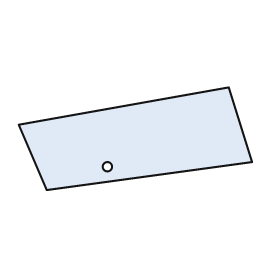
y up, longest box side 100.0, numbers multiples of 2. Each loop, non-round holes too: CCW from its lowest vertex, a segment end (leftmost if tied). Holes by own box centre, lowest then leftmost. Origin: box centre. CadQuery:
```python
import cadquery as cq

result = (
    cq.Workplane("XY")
    .moveTo(-38.0, -22.0)
    .lineTo(50.0, -10.0)
    .lineTo(40.0, 22.0)
    .lineTo(-50.0, 6.0)
    .close()
    .moveTo(-12.0, -12.0)
    .circle(2.0)
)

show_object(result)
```